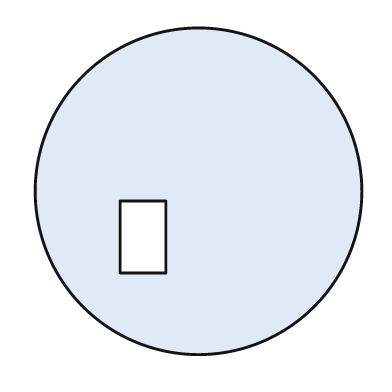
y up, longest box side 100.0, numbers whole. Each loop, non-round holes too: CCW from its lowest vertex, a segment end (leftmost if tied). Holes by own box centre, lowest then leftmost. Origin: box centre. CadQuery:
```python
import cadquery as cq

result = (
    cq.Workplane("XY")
    .moveTo(0.0, 0.0)
    .circle(50.0)
    .moveTo(-24.0, -25.0)
    .lineTo(-10.0, -25.0)
    .lineTo(-10.0, -3.0)
    .lineTo(-24.0, -3.0)
    .close()
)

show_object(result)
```